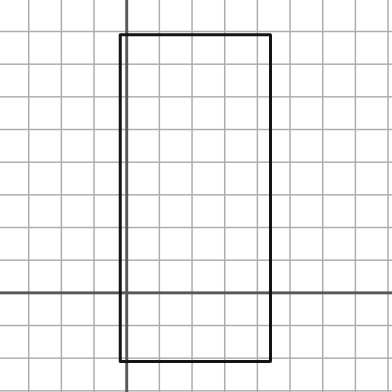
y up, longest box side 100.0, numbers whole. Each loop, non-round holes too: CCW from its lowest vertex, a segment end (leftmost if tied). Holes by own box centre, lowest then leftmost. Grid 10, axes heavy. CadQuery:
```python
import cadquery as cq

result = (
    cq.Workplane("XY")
    .moveTo(-2.0, -21.0)
    .lineTo(44.0, -21.0)
    .lineTo(44.0, 79.0)
    .lineTo(-2.0, 79.0)
    .close()
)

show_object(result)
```